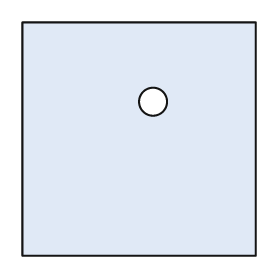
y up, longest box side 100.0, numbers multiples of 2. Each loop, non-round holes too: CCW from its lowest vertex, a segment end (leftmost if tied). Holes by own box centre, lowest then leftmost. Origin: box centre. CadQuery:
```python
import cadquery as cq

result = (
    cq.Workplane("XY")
    .moveTo(-50.0, -50.0)
    .lineTo(50.0, -50.0)
    .lineTo(50.0, 50.0)
    .lineTo(-50.0, 50.0)
    .close()
    .moveTo(6.0, 16.0)
    .circle(6.0)
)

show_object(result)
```